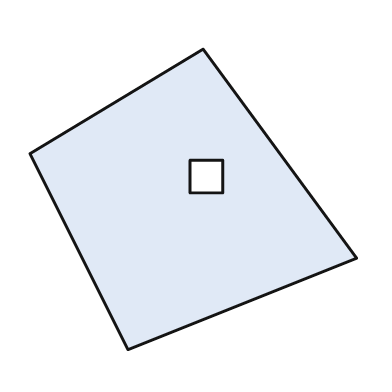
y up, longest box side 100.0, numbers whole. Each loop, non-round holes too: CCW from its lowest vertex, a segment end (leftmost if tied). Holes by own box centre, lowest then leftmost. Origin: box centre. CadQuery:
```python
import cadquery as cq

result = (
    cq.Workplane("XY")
    .moveTo(-20.0, -46.0)
    .lineTo(50.0, -18.0)
    .lineTo(3.0, 46.0)
    .lineTo(-50.0, 14.0)
    .close()
    .moveTo(-1.0, 2.0)
    .lineTo(9.0, 2.0)
    .lineTo(9.0, 12.0)
    .lineTo(-1.0, 12.0)
    .close()
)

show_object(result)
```